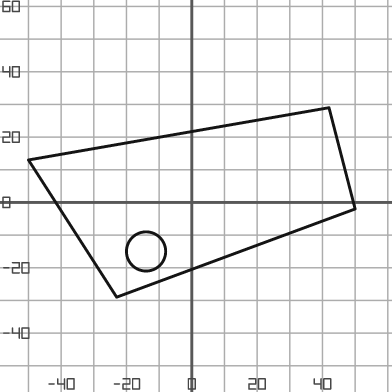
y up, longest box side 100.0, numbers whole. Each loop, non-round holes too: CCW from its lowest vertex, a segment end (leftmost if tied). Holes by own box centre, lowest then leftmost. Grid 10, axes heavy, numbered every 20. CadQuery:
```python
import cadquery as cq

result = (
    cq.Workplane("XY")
    .moveTo(-23.0, -29.0)
    .lineTo(50.0, -2.0)
    .lineTo(42.0, 29.0)
    .lineTo(-50.0, 13.0)
    .close()
    .moveTo(-14.0, -15.0)
    .circle(6.0)
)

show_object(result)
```